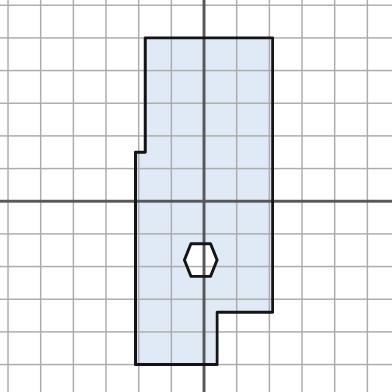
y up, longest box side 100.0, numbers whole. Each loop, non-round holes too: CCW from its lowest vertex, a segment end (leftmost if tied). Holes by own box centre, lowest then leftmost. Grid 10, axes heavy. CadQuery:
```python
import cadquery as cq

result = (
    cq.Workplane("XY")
    .moveTo(-21.0, -50.0)
    .lineTo(4.0, -50.0)
    .lineTo(4.0, -34.0)
    .lineTo(21.0, -34.0)
    .lineTo(21.0, 50.0)
    .lineTo(-18.0, 50.0)
    .lineTo(-18.0, 15.0)
    .lineTo(-21.0, 15.0)
    .close()
    .moveTo(-4.0, -23.0)
    .lineTo(2.0, -23.0)
    .lineTo(4.0, -18.0)
    .lineTo(2.0, -13.0)
    .lineTo(-4.0, -13.0)
    .lineTo(-6.0, -18.0)
    .close()
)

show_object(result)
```